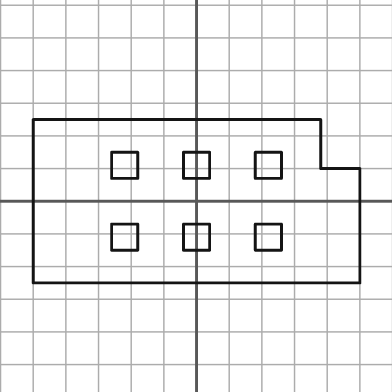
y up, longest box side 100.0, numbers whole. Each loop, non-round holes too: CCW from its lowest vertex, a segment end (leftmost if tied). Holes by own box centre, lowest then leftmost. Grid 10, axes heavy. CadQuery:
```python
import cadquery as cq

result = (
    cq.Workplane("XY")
    .moveTo(-50.0, -25.0)
    .lineTo(50.0, -25.0)
    .lineTo(50.0, 10.0)
    .lineTo(38.0, 10.0)
    .lineTo(38.0, 25.0)
    .lineTo(-50.0, 25.0)
    .close()
    .moveTo(-26.0, -15.0)
    .lineTo(-18.0, -15.0)
    .lineTo(-18.0, -7.0)
    .lineTo(-26.0, -7.0)
    .close()
    .moveTo(-4.0, -15.0)
    .lineTo(4.0, -15.0)
    .lineTo(4.0, -7.0)
    .lineTo(-4.0, -7.0)
    .close()
    .moveTo(18.0, -15.0)
    .lineTo(26.0, -15.0)
    .lineTo(26.0, -7.0)
    .lineTo(18.0, -7.0)
    .close()
    .moveTo(-26.0, 7.0)
    .lineTo(-18.0, 7.0)
    .lineTo(-18.0, 15.0)
    .lineTo(-26.0, 15.0)
    .close()
    .moveTo(-4.0, 7.0)
    .lineTo(4.0, 7.0)
    .lineTo(4.0, 15.0)
    .lineTo(-4.0, 15.0)
    .close()
    .moveTo(18.0, 7.0)
    .lineTo(26.0, 7.0)
    .lineTo(26.0, 15.0)
    .lineTo(18.0, 15.0)
    .close()
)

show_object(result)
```